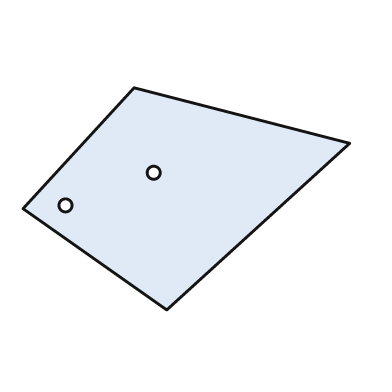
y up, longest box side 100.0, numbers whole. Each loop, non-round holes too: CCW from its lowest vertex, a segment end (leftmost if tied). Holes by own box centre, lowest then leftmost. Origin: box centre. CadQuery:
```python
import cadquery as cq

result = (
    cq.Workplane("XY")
    .moveTo(-6.0, -34.0)
    .lineTo(50.0, 17.0)
    .lineTo(-16.0, 34.0)
    .lineTo(-50.0, -3.0)
    .close()
    .moveTo(-37.0, -2.0)
    .circle(2.0)
    .moveTo(-10.0, 8.0)
    .circle(2.0)
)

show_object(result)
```